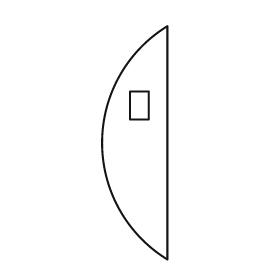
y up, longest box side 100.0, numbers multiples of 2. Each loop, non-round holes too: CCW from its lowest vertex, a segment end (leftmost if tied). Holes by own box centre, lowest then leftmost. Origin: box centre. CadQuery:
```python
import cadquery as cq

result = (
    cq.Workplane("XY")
    .moveTo(14.0, -50.0)
    .lineTo(14.0, 50.0)
    .threePointArc((-14.0, 0.0), (14.0, -50.0))
    .close()
    .moveTo(-2.0, 10.0)
    .lineTo(6.0, 10.0)
    .lineTo(6.0, 22.0)
    .lineTo(-2.0, 22.0)
    .close()
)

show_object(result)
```